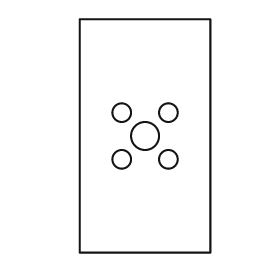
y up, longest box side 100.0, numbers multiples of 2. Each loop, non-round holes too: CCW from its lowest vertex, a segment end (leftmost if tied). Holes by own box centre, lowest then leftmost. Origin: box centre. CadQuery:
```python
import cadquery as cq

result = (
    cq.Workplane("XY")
    .moveTo(-28.0, -50.0)
    .lineTo(28.0, -50.0)
    .lineTo(28.0, 50.0)
    .lineTo(-28.0, 50.0)
    .close()
    .moveTo(-10.0, -10.0)
    .circle(4.0)
    .moveTo(10.0, -10.0)
    .circle(4.0)
    .moveTo(0.0, 0.0)
    .circle(6.0)
    .moveTo(-10.0, 10.0)
    .circle(4.0)
    .moveTo(10.0, 10.0)
    .circle(4.0)
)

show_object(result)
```